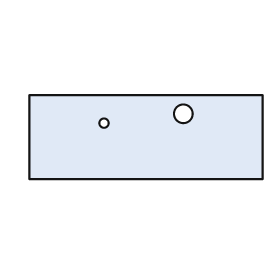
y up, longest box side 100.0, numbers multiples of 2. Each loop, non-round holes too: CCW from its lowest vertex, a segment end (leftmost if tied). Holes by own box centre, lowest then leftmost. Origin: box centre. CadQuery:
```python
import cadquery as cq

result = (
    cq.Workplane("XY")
    .moveTo(-50.0, -18.0)
    .lineTo(50.0, -18.0)
    .lineTo(50.0, 18.0)
    .lineTo(-50.0, 18.0)
    .close()
    .moveTo(-18.0, 6.0)
    .circle(2.0)
    .moveTo(16.0, 10.0)
    .circle(4.0)
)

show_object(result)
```